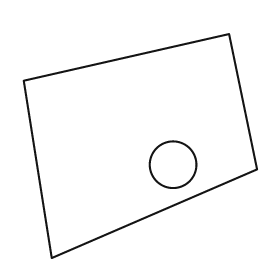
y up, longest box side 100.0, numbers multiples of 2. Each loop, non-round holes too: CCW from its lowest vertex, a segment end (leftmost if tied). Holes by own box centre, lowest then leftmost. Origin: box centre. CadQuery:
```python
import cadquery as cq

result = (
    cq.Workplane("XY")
    .moveTo(-38.0, -48.0)
    .lineTo(50.0, -10.0)
    .lineTo(38.0, 48.0)
    .lineTo(-50.0, 28.0)
    .close()
    .moveTo(14.0, -8.0)
    .circle(10.0)
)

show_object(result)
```